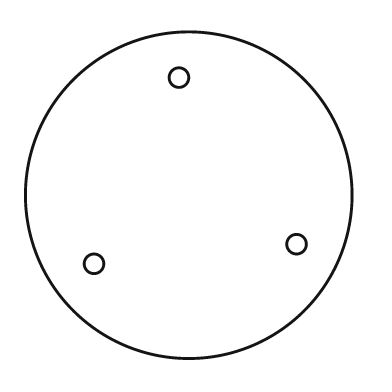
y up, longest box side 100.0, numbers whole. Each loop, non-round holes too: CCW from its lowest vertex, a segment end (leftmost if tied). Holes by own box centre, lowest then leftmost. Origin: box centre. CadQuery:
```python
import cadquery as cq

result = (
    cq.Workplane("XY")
    .moveTo(0.0, 0.0)
    .circle(50.0)
    .moveTo(-29.0, -21.0)
    .circle(3.0)
    .moveTo(33.0, -15.0)
    .circle(3.0)
    .moveTo(-3.0, 36.0)
    .circle(3.0)
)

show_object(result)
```